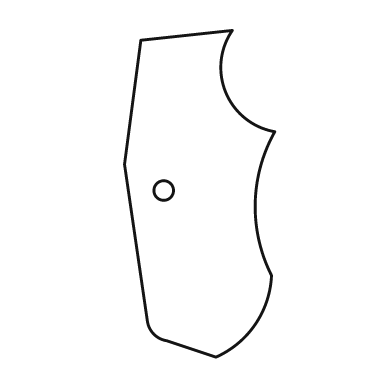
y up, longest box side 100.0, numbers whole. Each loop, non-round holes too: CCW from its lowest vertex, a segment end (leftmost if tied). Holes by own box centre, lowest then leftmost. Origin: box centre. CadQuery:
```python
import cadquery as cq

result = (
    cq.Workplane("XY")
    .moveTo(5.0, -50.0)
    .threePointArc((17.0, -40.0), (22.0, -25.0))
    .threePointArc((17.0, -3.0), (23.0, 19.0))
    .threePointArc((8.0, 31.0), (10.0, 50.0))
    .lineTo(-18.0, 47.0)
    .lineTo(-23.0, 9.0)
    .lineTo(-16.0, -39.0)
    .threePointArc((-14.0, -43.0), (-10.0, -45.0))
    .close()
    .moveTo(-11.0, 1.0)
    .circle(3.0)
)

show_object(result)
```